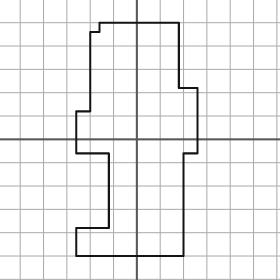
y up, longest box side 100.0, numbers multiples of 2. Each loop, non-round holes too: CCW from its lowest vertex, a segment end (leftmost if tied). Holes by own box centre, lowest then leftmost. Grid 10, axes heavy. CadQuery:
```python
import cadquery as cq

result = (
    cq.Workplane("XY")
    .moveTo(-26.0, -50.0)
    .lineTo(20.0, -50.0)
    .lineTo(20.0, -6.0)
    .lineTo(26.0, -6.0)
    .lineTo(26.0, 22.0)
    .lineTo(18.0, 22.0)
    .lineTo(18.0, 50.0)
    .lineTo(-16.0, 50.0)
    .lineTo(-16.0, 46.0)
    .lineTo(-20.0, 46.0)
    .lineTo(-20.0, 12.0)
    .lineTo(-26.0, 12.0)
    .lineTo(-26.0, -6.0)
    .lineTo(-12.0, -6.0)
    .lineTo(-12.0, -38.0)
    .lineTo(-26.0, -38.0)
    .close()
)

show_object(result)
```